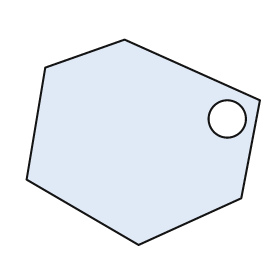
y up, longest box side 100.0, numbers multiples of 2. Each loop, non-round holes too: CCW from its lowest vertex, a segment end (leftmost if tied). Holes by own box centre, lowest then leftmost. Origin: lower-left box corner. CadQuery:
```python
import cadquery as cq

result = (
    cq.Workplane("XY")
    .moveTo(48.0, 0.0)
    .lineTo(92.0, 20.0)
    .lineTo(100.0, 62.0)
    .lineTo(42.0, 88.0)
    .lineTo(8.0, 76.0)
    .lineTo(0.0, 28.0)
    .close()
    .moveTo(86.0, 54.0)
    .circle(8.0)
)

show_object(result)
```